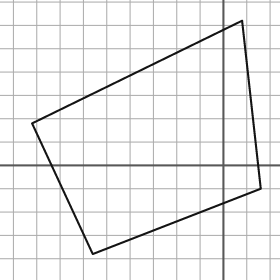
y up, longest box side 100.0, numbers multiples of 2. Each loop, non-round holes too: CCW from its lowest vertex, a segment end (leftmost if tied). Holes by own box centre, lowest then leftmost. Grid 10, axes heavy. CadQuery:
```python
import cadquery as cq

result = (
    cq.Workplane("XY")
    .moveTo(-56.0, -38.0)
    .lineTo(16.0, -10.0)
    .lineTo(8.0, 62.0)
    .lineTo(-82.0, 18.0)
    .close()
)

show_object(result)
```